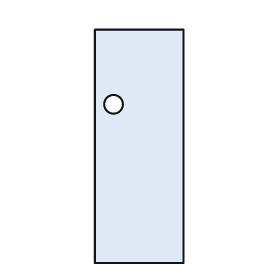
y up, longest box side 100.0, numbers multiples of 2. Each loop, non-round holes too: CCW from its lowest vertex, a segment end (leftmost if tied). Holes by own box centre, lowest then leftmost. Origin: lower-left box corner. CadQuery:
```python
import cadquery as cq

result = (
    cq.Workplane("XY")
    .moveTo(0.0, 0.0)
    .lineTo(38.0, 0.0)
    .lineTo(38.0, 100.0)
    .lineTo(0.0, 100.0)
    .close()
    .moveTo(8.0, 68.0)
    .circle(4.0)
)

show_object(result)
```